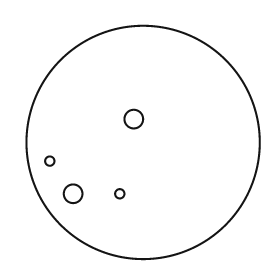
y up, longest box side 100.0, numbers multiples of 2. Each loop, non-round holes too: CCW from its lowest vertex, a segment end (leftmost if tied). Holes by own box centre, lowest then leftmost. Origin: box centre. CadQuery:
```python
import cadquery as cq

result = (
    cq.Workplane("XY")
    .moveTo(0.0, 0.0)
    .circle(50.0)
    .moveTo(-30.0, -22.0)
    .circle(4.0)
    .moveTo(-10.0, -22.0)
    .circle(2.0)
    .moveTo(-40.0, -8.0)
    .circle(2.0)
    .moveTo(-4.0, 10.0)
    .circle(4.0)
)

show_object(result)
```